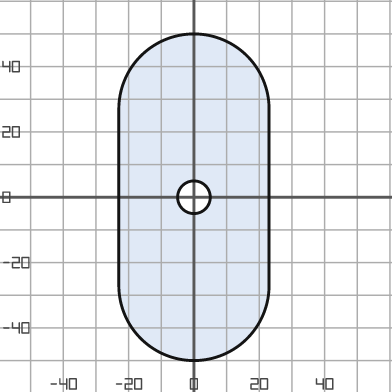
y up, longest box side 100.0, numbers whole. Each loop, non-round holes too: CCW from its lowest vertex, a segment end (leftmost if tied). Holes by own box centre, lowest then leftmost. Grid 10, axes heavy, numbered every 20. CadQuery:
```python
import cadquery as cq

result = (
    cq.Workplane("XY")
    .moveTo(-23.0, -27.0)
    .threePointArc((0.0, -50.0), (23.0, -27.0))
    .lineTo(23.0, 27.0)
    .threePointArc((0.0, 50.0), (-23.0, 27.0))
    .close()
    .moveTo(0.0, 0.0)
    .circle(5.0)
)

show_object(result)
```